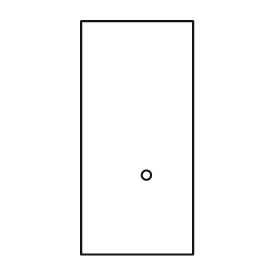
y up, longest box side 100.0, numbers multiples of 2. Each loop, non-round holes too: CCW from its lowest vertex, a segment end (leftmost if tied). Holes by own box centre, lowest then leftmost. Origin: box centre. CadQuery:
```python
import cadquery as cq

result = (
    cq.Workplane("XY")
    .moveTo(-24.0, -50.0)
    .lineTo(24.0, -50.0)
    .lineTo(24.0, 50.0)
    .lineTo(-24.0, 50.0)
    .close()
    .moveTo(4.0, -16.0)
    .circle(2.0)
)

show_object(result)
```